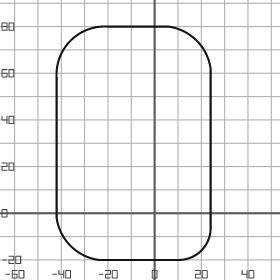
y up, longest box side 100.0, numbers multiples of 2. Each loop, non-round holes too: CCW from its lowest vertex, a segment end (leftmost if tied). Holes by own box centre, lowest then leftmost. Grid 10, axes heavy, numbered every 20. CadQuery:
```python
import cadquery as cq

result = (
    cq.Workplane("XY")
    .moveTo(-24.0, -20.0)
    .lineTo(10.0, -20.0)
    .threePointArc((20.0, -16.0), (24.0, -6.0))
    .lineTo(24.0, 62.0)
    .threePointArc((18.0, 74.0), (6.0, 80.0))
    .lineTo(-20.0, 80.0)
    .threePointArc((-36.0, 74.0), (-42.0, 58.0))
    .lineTo(-42.0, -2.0)
    .threePointArc((-36.0, -14.0), (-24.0, -20.0))
    .close()
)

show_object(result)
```